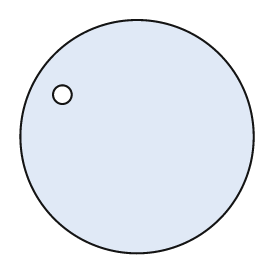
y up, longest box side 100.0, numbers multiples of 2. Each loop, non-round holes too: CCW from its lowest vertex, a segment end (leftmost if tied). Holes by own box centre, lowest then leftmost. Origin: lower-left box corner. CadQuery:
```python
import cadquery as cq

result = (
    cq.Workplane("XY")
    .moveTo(50.0, 50.0)
    .circle(50.0)
    .moveTo(18.0, 68.0)
    .circle(4.0)
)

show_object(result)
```